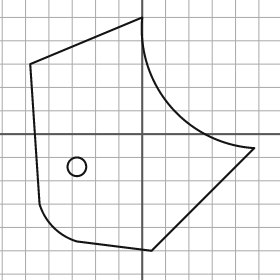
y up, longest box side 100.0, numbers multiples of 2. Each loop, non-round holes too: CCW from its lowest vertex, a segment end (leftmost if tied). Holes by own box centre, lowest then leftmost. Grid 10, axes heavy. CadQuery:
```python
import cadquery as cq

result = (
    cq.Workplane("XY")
    .moveTo(4.0, -50.0)
    .lineTo(48.0, -6.0)
    .threePointArc((12.0, 12.0), (0.0, 50.0))
    .lineTo(-48.0, 30.0)
    .lineTo(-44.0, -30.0)
    .threePointArc((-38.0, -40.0), (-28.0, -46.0))
    .close()
    .moveTo(-28.0, -14.0)
    .circle(4.0)
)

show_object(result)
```